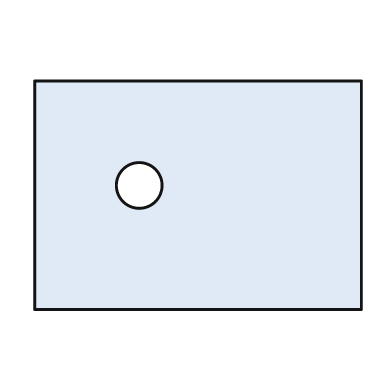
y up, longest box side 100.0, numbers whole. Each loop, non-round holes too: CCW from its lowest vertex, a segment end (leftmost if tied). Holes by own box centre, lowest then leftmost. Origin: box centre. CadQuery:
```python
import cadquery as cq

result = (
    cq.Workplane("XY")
    .moveTo(-50.0, -35.0)
    .lineTo(50.0, -35.0)
    .lineTo(50.0, 35.0)
    .lineTo(-50.0, 35.0)
    .close()
    .moveTo(-18.0, 3.0)
    .circle(7.0)
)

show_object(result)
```